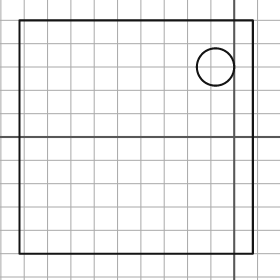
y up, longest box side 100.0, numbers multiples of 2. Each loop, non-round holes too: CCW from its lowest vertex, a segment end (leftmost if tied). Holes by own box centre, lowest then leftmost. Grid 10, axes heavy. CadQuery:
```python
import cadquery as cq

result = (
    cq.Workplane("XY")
    .moveTo(-92.0, -50.0)
    .lineTo(8.0, -50.0)
    .lineTo(8.0, 50.0)
    .lineTo(-92.0, 50.0)
    .close()
    .moveTo(-8.0, 30.0)
    .circle(8.0)
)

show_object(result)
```